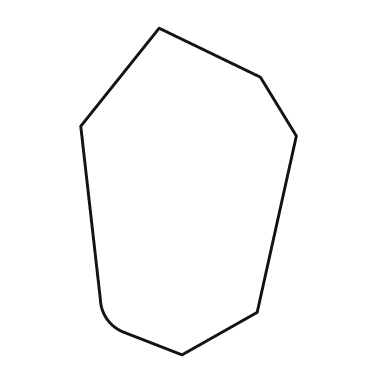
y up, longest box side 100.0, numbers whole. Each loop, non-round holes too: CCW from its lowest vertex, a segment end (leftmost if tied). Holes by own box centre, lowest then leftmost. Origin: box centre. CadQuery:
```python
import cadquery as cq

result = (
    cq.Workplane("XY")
    .moveTo(-2.0, -50.0)
    .lineTo(21.0, -37.0)
    .lineTo(33.0, 17.0)
    .lineTo(22.0, 35.0)
    .lineTo(-9.0, 50.0)
    .lineTo(-33.0, 20.0)
    .lineTo(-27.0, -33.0)
    .threePointArc((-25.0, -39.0), (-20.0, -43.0))
    .close()
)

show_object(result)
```